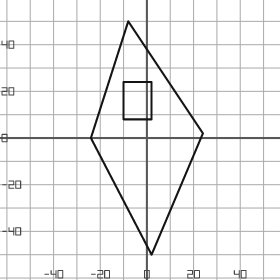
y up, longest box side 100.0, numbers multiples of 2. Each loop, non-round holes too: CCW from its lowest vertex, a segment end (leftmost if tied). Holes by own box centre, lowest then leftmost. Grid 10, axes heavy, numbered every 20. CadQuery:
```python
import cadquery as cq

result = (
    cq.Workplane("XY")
    .moveTo(2.0, -50.0)
    .lineTo(24.0, 2.0)
    .lineTo(-8.0, 50.0)
    .lineTo(-24.0, 0.0)
    .close()
    .moveTo(-10.0, 8.0)
    .lineTo(2.0, 8.0)
    .lineTo(2.0, 24.0)
    .lineTo(-10.0, 24.0)
    .close()
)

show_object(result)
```